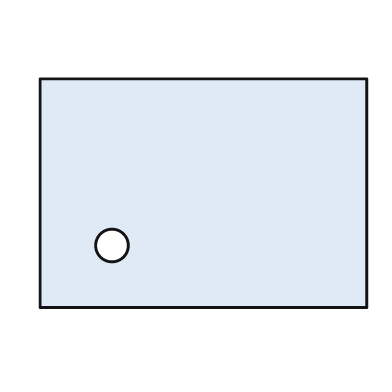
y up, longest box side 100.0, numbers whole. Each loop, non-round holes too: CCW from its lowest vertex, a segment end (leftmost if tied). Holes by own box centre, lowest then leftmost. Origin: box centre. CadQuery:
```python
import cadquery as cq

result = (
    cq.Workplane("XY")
    .moveTo(-50.0, -35.0)
    .lineTo(50.0, -35.0)
    .lineTo(50.0, 35.0)
    .lineTo(-50.0, 35.0)
    .close()
    .moveTo(-28.0, -16.0)
    .circle(5.0)
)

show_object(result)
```